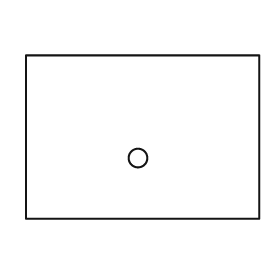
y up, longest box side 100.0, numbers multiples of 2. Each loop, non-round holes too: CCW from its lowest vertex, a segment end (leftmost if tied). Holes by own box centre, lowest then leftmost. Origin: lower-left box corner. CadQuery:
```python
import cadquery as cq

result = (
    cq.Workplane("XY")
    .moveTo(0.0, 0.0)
    .lineTo(100.0, 0.0)
    .lineTo(100.0, 70.0)
    .lineTo(0.0, 70.0)
    .close()
    .moveTo(48.0, 26.0)
    .circle(4.0)
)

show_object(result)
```